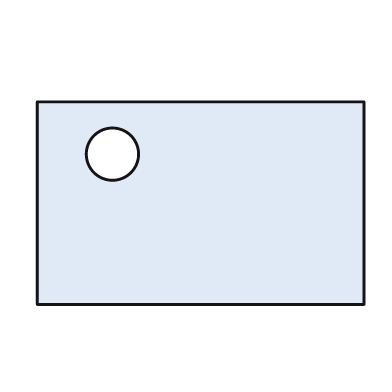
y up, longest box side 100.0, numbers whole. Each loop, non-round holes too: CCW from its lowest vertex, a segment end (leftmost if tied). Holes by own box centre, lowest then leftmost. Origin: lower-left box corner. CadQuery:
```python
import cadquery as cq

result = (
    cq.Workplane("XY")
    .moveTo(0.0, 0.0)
    .lineTo(100.0, 0.0)
    .lineTo(100.0, 62.0)
    .lineTo(0.0, 62.0)
    .close()
    .moveTo(23.0, 46.0)
    .circle(8.0)
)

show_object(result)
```